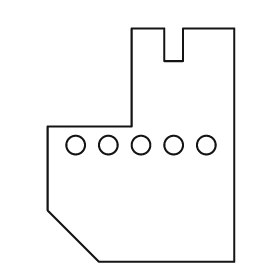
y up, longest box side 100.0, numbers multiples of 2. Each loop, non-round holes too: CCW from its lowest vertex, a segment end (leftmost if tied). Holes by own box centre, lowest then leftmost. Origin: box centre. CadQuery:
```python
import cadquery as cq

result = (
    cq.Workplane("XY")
    .moveTo(-18.0, -50.0)
    .lineTo(40.0, -50.0)
    .lineTo(40.0, 50.0)
    .lineTo(18.0, 50.0)
    .lineTo(18.0, 36.0)
    .lineTo(10.0, 36.0)
    .lineTo(10.0, 50.0)
    .lineTo(-4.0, 50.0)
    .lineTo(-4.0, 8.0)
    .lineTo(-40.0, 8.0)
    .lineTo(-40.0, -28.0)
    .close()
    .moveTo(-28.0, 0.0)
    .circle(4.0)
    .moveTo(-14.0, 0.0)
    .circle(4.0)
    .moveTo(0.0, 0.0)
    .circle(4.0)
    .moveTo(14.0, 0.0)
    .circle(4.0)
    .moveTo(28.0, 0.0)
    .circle(4.0)
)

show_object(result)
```